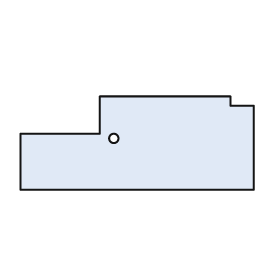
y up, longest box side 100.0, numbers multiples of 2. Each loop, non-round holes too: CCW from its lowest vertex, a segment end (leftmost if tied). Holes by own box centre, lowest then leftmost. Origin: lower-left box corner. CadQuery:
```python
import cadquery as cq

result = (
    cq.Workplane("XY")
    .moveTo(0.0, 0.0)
    .lineTo(100.0, 0.0)
    .lineTo(100.0, 36.0)
    .lineTo(90.0, 36.0)
    .lineTo(90.0, 40.0)
    .lineTo(34.0, 40.0)
    .lineTo(34.0, 24.0)
    .lineTo(0.0, 24.0)
    .close()
    .moveTo(40.0, 22.0)
    .circle(2.0)
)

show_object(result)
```